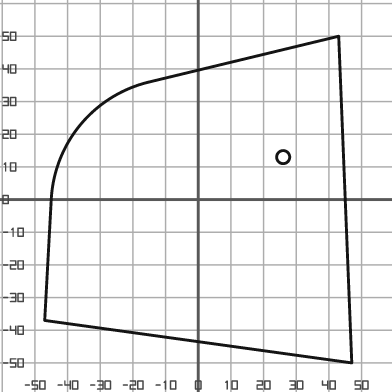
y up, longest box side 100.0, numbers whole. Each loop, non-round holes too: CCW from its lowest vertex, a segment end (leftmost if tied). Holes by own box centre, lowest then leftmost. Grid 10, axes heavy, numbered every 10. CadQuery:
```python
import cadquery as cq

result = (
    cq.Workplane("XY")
    .moveTo(47.0, -50.0)
    .lineTo(43.0, 50.0)
    .lineTo(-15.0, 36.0)
    .threePointArc((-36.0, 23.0), (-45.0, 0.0))
    .lineTo(-47.0, -37.0)
    .close()
    .moveTo(26.0, 13.0)
    .circle(2.0)
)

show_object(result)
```